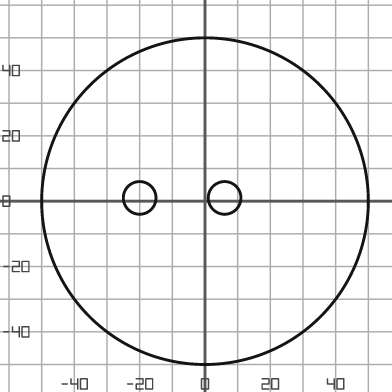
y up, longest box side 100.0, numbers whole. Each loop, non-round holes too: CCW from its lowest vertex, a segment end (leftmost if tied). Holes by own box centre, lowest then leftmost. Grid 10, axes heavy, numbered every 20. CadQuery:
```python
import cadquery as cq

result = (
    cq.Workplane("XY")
    .moveTo(0.0, 0.0)
    .circle(50.0)
    .moveTo(-20.0, 1.0)
    .circle(5.0)
    .moveTo(6.0, 1.0)
    .circle(5.0)
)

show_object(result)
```